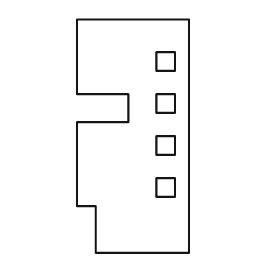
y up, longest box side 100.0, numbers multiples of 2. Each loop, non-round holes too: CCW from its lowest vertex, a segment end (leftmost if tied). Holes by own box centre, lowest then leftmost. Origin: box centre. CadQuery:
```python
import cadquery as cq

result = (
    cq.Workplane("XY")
    .moveTo(-16.0, -50.0)
    .lineTo(24.0, -50.0)
    .lineTo(24.0, 50.0)
    .lineTo(-24.0, 50.0)
    .lineTo(-24.0, 18.0)
    .lineTo(-2.0, 18.0)
    .lineTo(-2.0, 6.0)
    .lineTo(-24.0, 6.0)
    .lineTo(-24.0, -30.0)
    .lineTo(-16.0, -30.0)
    .close()
    .moveTo(10.0, -26.0)
    .lineTo(18.0, -26.0)
    .lineTo(18.0, -18.0)
    .lineTo(10.0, -18.0)
    .close()
    .moveTo(10.0, -8.0)
    .lineTo(18.0, -8.0)
    .lineTo(18.0, 0.0)
    .lineTo(10.0, 0.0)
    .close()
    .moveTo(10.0, 10.0)
    .lineTo(18.0, 10.0)
    .lineTo(18.0, 18.0)
    .lineTo(10.0, 18.0)
    .close()
    .moveTo(10.0, 28.0)
    .lineTo(18.0, 28.0)
    .lineTo(18.0, 36.0)
    .lineTo(10.0, 36.0)
    .close()
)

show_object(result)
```